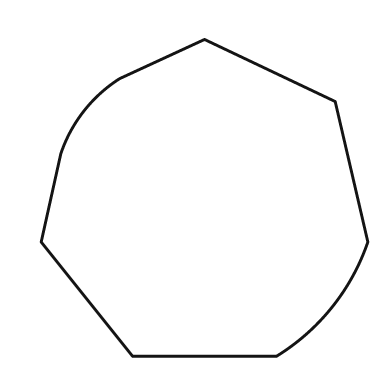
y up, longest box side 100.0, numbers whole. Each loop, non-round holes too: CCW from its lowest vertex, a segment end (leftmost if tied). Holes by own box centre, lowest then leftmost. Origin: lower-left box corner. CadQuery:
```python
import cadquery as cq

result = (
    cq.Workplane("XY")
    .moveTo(28.0, 0.0)
    .lineTo(72.0, 0.0)
    .threePointArc((89.0, 15.0), (100.0, 35.0))
    .lineTo(90.0, 78.0)
    .lineTo(50.0, 97.0)
    .lineTo(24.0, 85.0)
    .threePointArc((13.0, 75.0), (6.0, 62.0))
    .lineTo(0.0, 35.0)
    .close()
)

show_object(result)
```